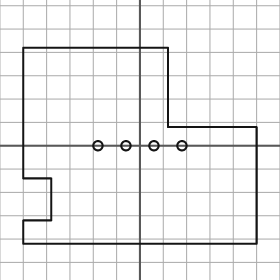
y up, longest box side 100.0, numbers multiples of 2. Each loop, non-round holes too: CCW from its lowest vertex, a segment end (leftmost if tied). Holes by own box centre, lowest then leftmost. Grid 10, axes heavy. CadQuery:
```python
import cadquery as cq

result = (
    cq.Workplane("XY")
    .moveTo(-50.0, -42.0)
    .lineTo(50.0, -42.0)
    .lineTo(50.0, 8.0)
    .lineTo(12.0, 8.0)
    .lineTo(12.0, 42.0)
    .lineTo(-50.0, 42.0)
    .lineTo(-50.0, -14.0)
    .lineTo(-38.0, -14.0)
    .lineTo(-38.0, -32.0)
    .lineTo(-50.0, -32.0)
    .close()
    .moveTo(-18.0, 0.0)
    .circle(2.0)
    .moveTo(-6.0, 0.0)
    .circle(2.0)
    .moveTo(6.0, 0.0)
    .circle(2.0)
    .moveTo(18.0, 0.0)
    .circle(2.0)
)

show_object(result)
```